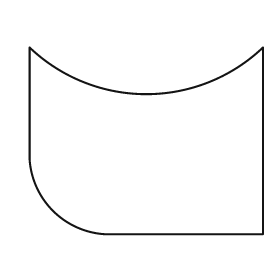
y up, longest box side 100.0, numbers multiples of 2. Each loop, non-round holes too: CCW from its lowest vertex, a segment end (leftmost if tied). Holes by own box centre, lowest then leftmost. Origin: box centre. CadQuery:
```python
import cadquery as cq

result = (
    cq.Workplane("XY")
    .moveTo(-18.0, -40.0)
    .lineTo(50.0, -40.0)
    .lineTo(50.0, 40.0)
    .threePointArc((0.0, 20.0), (-50.0, 40.0))
    .lineTo(-50.0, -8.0)
    .threePointArc((-40.0, -30.0), (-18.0, -40.0))
    .close()
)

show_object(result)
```